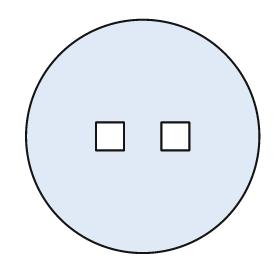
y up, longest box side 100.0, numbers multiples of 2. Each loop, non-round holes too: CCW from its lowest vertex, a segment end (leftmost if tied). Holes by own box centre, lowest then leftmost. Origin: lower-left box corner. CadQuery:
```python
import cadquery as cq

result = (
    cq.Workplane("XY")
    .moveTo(50.0, 50.0)
    .circle(50.0)
    .moveTo(30.0, 44.0)
    .lineTo(42.0, 44.0)
    .lineTo(42.0, 56.0)
    .lineTo(30.0, 56.0)
    .close()
    .moveTo(58.0, 44.0)
    .lineTo(70.0, 44.0)
    .lineTo(70.0, 56.0)
    .lineTo(58.0, 56.0)
    .close()
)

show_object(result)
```